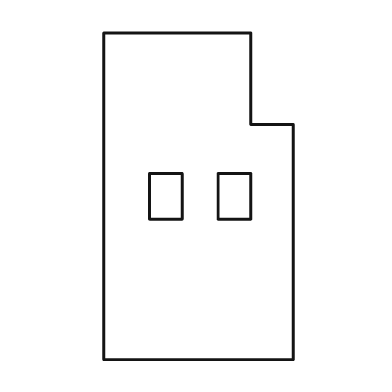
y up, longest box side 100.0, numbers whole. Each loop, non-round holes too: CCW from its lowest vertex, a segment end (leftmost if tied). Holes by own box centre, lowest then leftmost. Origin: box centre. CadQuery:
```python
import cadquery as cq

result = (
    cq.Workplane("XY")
    .moveTo(-29.0, -50.0)
    .lineTo(29.0, -50.0)
    .lineTo(29.0, 22.0)
    .lineTo(16.0, 22.0)
    .lineTo(16.0, 50.0)
    .lineTo(-29.0, 50.0)
    .close()
    .moveTo(-15.0, -7.0)
    .lineTo(-5.0, -7.0)
    .lineTo(-5.0, 7.0)
    .lineTo(-15.0, 7.0)
    .close()
    .moveTo(6.0, -7.0)
    .lineTo(16.0, -7.0)
    .lineTo(16.0, 7.0)
    .lineTo(6.0, 7.0)
    .close()
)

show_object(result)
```